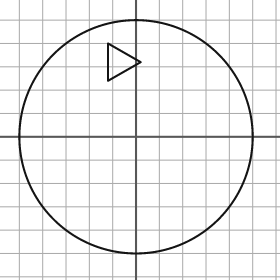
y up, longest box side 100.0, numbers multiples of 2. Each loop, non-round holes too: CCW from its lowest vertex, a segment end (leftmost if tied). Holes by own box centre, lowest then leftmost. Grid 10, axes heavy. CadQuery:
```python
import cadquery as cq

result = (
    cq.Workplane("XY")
    .moveTo(0.0, 0.0)
    .circle(50.0)
    .moveTo(-12.0, 24.0)
    .lineTo(2.0, 32.0)
    .lineTo(-12.0, 40.0)
    .close()
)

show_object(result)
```